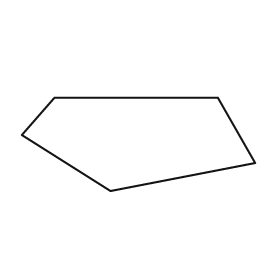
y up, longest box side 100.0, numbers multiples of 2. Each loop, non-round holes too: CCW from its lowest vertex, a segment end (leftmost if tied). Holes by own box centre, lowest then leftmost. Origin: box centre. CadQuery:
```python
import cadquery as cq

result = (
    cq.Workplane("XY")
    .moveTo(-12.0, -20.0)
    .lineTo(50.0, -8.0)
    .lineTo(34.0, 20.0)
    .lineTo(-36.0, 20.0)
    .lineTo(-50.0, 4.0)
    .close()
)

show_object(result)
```